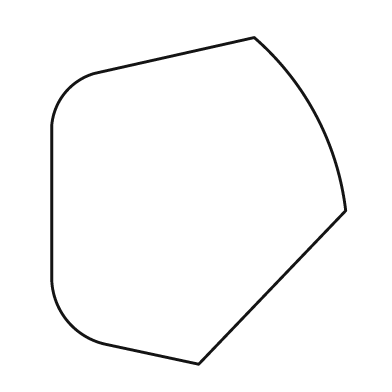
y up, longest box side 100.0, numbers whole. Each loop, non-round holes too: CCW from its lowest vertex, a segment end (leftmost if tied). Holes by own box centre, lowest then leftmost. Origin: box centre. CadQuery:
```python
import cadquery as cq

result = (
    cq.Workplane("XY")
    .moveTo(0.0, -50.0)
    .lineTo(45.0, -3.0)
    .threePointArc((36.0, 26.0), (17.0, 50.0))
    .lineTo(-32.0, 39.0)
    .threePointArc((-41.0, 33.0), (-45.0, 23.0))
    .lineTo(-45.0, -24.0)
    .threePointArc((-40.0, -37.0), (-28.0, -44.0))
    .close()
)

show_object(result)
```